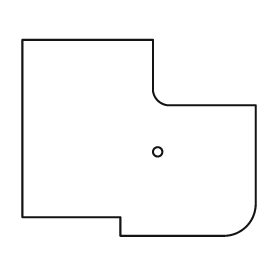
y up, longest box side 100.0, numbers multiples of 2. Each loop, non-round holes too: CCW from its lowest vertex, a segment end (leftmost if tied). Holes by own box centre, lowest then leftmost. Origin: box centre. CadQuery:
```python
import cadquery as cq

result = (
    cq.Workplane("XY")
    .moveTo(-8.0, -42.0)
    .lineTo(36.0, -42.0)
    .threePointArc((46.0, -38.0), (50.0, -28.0))
    .lineTo(50.0, 14.0)
    .lineTo(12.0, 14.0)
    .threePointArc((8.0, 16.0), (6.0, 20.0))
    .lineTo(6.0, 42.0)
    .lineTo(-50.0, 42.0)
    .lineTo(-50.0, -34.0)
    .lineTo(-8.0, -34.0)
    .close()
    .moveTo(8.0, -6.0)
    .circle(2.0)
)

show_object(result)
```